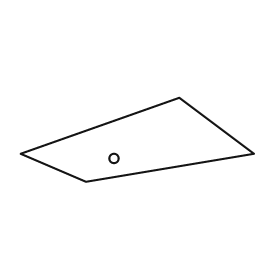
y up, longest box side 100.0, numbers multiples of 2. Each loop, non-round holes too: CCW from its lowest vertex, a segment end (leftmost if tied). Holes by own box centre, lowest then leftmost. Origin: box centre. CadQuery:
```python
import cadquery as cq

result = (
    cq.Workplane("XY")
    .moveTo(-22.0, -18.0)
    .lineTo(50.0, -6.0)
    .lineTo(18.0, 18.0)
    .lineTo(-50.0, -6.0)
    .close()
    .moveTo(-10.0, -8.0)
    .circle(2.0)
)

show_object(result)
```